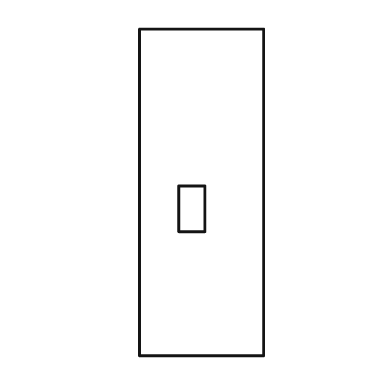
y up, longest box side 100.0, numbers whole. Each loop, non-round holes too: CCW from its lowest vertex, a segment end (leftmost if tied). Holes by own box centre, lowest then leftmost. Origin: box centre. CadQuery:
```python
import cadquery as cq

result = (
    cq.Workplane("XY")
    .moveTo(-19.0, -50.0)
    .lineTo(19.0, -50.0)
    .lineTo(19.0, 50.0)
    .lineTo(-19.0, 50.0)
    .close()
    .moveTo(-7.0, -12.0)
    .lineTo(1.0, -12.0)
    .lineTo(1.0, 2.0)
    .lineTo(-7.0, 2.0)
    .close()
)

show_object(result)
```